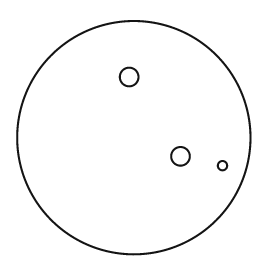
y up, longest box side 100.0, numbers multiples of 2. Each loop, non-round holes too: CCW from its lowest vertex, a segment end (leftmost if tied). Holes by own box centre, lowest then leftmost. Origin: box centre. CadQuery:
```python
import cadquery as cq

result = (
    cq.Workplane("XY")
    .moveTo(0.0, 0.0)
    .circle(50.0)
    .moveTo(38.0, -12.0)
    .circle(2.0)
    .moveTo(20.0, -8.0)
    .circle(4.0)
    .moveTo(-2.0, 26.0)
    .circle(4.0)
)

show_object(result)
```